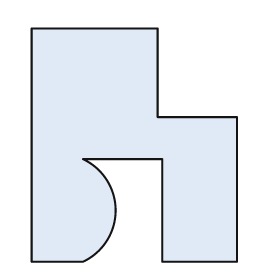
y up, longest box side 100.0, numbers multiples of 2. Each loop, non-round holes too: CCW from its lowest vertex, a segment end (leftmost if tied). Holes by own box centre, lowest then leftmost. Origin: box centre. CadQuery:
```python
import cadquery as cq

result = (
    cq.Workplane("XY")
    .moveTo(-44.0, -50.0)
    .lineTo(-22.0, -50.0)
    .threePointArc((-8.0, -28.0), (-22.0, -6.0))
    .lineTo(12.0, -6.0)
    .lineTo(12.0, -50.0)
    .lineTo(44.0, -50.0)
    .lineTo(44.0, 12.0)
    .lineTo(10.0, 12.0)
    .lineTo(10.0, 50.0)
    .lineTo(-44.0, 50.0)
    .close()
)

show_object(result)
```